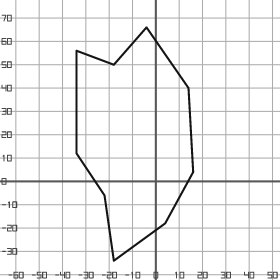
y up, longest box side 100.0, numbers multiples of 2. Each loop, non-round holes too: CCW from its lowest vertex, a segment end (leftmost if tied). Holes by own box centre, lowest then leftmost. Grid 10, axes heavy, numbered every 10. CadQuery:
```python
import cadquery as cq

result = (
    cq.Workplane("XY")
    .moveTo(-18.0, -34.0)
    .lineTo(4.0, -18.0)
    .lineTo(16.0, 4.0)
    .lineTo(14.0, 40.0)
    .lineTo(-4.0, 66.0)
    .lineTo(-18.0, 50.0)
    .lineTo(-34.0, 56.0)
    .lineTo(-34.0, 12.0)
    .lineTo(-22.0, -6.0)
    .close()
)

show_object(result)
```